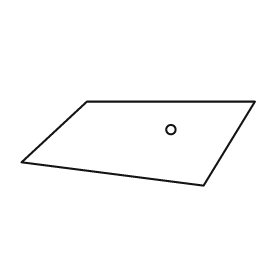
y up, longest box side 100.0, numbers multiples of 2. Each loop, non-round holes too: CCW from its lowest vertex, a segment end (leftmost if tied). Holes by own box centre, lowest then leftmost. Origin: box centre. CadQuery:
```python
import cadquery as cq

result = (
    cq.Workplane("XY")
    .moveTo(28.0, -18.0)
    .lineTo(50.0, 18.0)
    .lineTo(-22.0, 18.0)
    .lineTo(-50.0, -8.0)
    .close()
    .moveTo(14.0, 6.0)
    .circle(2.0)
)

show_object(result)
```